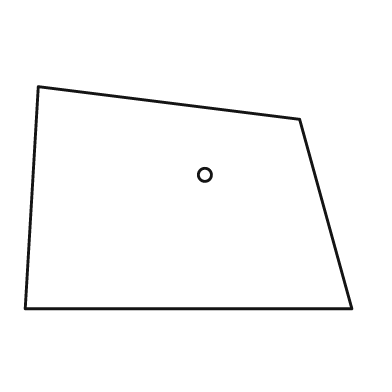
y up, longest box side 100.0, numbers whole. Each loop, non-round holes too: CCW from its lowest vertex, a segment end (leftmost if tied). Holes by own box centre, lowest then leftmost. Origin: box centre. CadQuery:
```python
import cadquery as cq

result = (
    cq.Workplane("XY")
    .moveTo(-50.0, -34.0)
    .lineTo(50.0, -34.0)
    .lineTo(34.0, 24.0)
    .lineTo(-46.0, 34.0)
    .close()
    .moveTo(5.0, 7.0)
    .circle(2.0)
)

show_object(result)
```